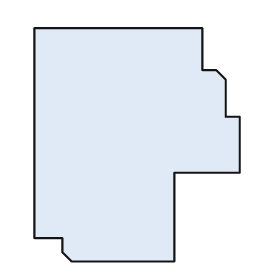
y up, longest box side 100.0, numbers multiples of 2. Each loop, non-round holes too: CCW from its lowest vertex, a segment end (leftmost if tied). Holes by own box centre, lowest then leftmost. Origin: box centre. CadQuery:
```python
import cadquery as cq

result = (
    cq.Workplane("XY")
    .moveTo(-28.0, -50.0)
    .lineTo(16.0, -50.0)
    .lineTo(16.0, -12.0)
    .lineTo(44.0, -12.0)
    .lineTo(44.0, 12.0)
    .lineTo(38.0, 12.0)
    .lineTo(38.0, 28.0)
    .lineTo(34.0, 32.0)
    .lineTo(28.0, 32.0)
    .lineTo(28.0, 50.0)
    .lineTo(-44.0, 50.0)
    .lineTo(-44.0, -40.0)
    .lineTo(-32.0, -40.0)
    .lineTo(-32.0, -46.0)
    .close()
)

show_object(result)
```